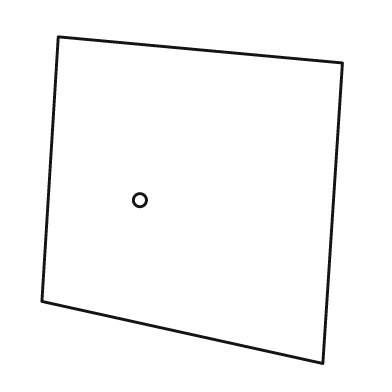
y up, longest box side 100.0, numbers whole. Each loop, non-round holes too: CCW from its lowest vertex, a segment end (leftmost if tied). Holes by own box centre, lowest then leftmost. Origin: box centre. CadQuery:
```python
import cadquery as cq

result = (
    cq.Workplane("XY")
    .moveTo(40.0, -50.0)
    .lineTo(46.0, 42.0)
    .lineTo(-41.0, 50.0)
    .lineTo(-46.0, -31.0)
    .close()
    .moveTo(-16.0, 0.0)
    .circle(2.0)
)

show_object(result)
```